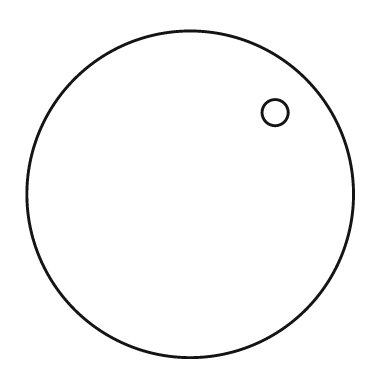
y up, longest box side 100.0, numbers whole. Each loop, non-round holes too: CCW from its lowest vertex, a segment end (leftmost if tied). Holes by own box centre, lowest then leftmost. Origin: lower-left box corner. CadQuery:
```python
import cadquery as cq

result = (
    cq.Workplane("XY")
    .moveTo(50.0, 50.0)
    .circle(50.0)
    .moveTo(76.0, 75.0)
    .circle(4.0)
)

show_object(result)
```